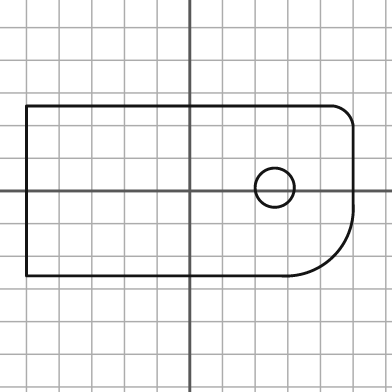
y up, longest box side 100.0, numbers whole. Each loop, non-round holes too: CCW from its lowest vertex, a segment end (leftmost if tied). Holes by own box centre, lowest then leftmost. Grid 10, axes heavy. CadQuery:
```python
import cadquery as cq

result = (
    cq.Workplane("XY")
    .moveTo(-50.0, -26.0)
    .lineTo(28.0, -26.0)
    .threePointArc((44.0, -20.0), (50.0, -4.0))
    .lineTo(50.0, 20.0)
    .threePointArc((48.0, 24.0), (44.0, 26.0))
    .lineTo(-50.0, 26.0)
    .close()
    .moveTo(26.0, 1.0)
    .circle(6.0)
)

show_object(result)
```